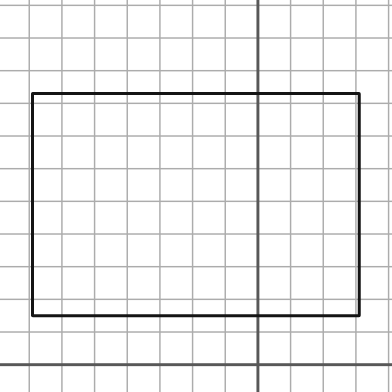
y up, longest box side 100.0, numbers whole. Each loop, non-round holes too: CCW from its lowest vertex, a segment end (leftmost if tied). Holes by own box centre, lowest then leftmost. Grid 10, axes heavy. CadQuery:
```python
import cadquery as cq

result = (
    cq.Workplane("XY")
    .moveTo(-69.0, 15.0)
    .lineTo(31.0, 15.0)
    .lineTo(31.0, 83.0)
    .lineTo(-69.0, 83.0)
    .close()
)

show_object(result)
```